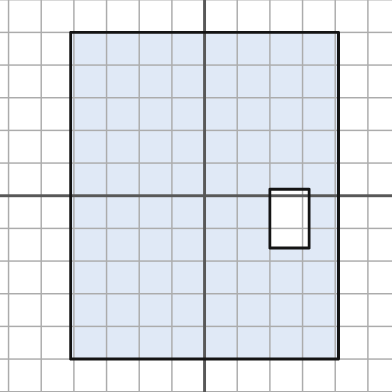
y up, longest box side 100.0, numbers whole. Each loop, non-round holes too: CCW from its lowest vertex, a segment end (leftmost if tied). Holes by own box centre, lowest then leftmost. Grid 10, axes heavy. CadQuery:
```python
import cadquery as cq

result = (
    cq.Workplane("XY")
    .moveTo(-41.0, -50.0)
    .lineTo(41.0, -50.0)
    .lineTo(41.0, 50.0)
    .lineTo(-41.0, 50.0)
    .close()
    .moveTo(20.0, -16.0)
    .lineTo(32.0, -16.0)
    .lineTo(32.0, 2.0)
    .lineTo(20.0, 2.0)
    .close()
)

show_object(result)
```